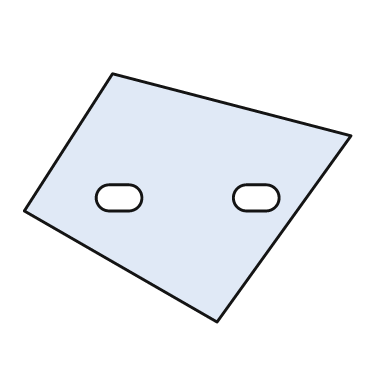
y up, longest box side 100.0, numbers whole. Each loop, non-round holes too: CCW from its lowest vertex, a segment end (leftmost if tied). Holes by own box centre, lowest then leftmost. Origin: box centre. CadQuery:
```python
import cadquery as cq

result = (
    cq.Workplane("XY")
    .moveTo(9.0, -38.0)
    .lineTo(50.0, 19.0)
    .lineTo(-23.0, 38.0)
    .lineTo(-50.0, -4.0)
    .close()
    .moveTo(-24.0, -4.0)
    .lineTo(-18.0, -4.0)
    .threePointArc((-14.0, 0.0), (-18.0, 4.0))
    .lineTo(-24.0, 4.0)
    .threePointArc((-28.0, 0.0), (-24.0, -4.0))
    .close()
    .moveTo(18.0, -4.0)
    .lineTo(24.0, -4.0)
    .threePointArc((28.0, 0.0), (24.0, 4.0))
    .lineTo(18.0, 4.0)
    .threePointArc((14.0, 0.0), (18.0, -4.0))
    .close()
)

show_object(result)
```